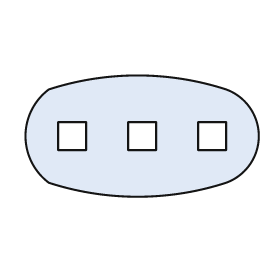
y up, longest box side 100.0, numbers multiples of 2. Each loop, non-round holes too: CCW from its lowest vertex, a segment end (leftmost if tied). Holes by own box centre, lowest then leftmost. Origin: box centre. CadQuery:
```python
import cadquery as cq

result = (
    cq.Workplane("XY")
    .moveTo(-40.0, -20.0)
    .threePointArc((-2.0, -26.0), (36.0, -20.0))
    .threePointArc((50.0, 0.0), (36.0, 20.0))
    .threePointArc((-2.0, 26.0), (-40.0, 20.0))
    .threePointArc((-50.0, 0.0), (-40.0, -20.0))
    .close()
    .moveTo(-36.0, -6.0)
    .lineTo(-24.0, -6.0)
    .lineTo(-24.0, 6.0)
    .lineTo(-36.0, 6.0)
    .close()
    .moveTo(-6.0, -6.0)
    .lineTo(6.0, -6.0)
    .lineTo(6.0, 6.0)
    .lineTo(-6.0, 6.0)
    .close()
    .moveTo(24.0, -6.0)
    .lineTo(36.0, -6.0)
    .lineTo(36.0, 6.0)
    .lineTo(24.0, 6.0)
    .close()
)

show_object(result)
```